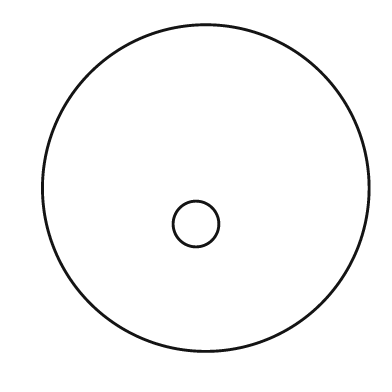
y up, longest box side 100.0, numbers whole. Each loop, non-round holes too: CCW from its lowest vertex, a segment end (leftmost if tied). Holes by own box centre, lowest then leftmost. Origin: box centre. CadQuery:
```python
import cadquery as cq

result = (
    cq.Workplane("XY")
    .moveTo(0.0, 0.0)
    .circle(50.0)
    .moveTo(-3.0, -11.0)
    .circle(7.0)
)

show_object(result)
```